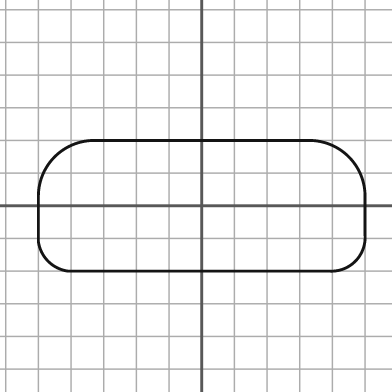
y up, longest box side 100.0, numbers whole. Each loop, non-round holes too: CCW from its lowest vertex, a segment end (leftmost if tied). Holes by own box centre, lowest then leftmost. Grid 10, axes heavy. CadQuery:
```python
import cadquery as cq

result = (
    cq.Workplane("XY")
    .moveTo(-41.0, -20.0)
    .lineTo(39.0, -20.0)
    .threePointArc((47.0, -17.0), (50.0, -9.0))
    .lineTo(50.0, 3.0)
    .threePointArc((45.0, 15.0), (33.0, 20.0))
    .lineTo(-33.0, 20.0)
    .threePointArc((-45.0, 15.0), (-50.0, 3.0))
    .lineTo(-50.0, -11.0)
    .threePointArc((-47.0, -17.0), (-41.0, -20.0))
    .close()
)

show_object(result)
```